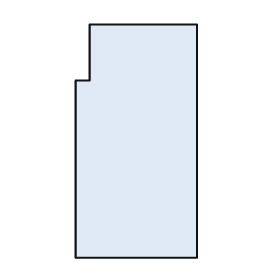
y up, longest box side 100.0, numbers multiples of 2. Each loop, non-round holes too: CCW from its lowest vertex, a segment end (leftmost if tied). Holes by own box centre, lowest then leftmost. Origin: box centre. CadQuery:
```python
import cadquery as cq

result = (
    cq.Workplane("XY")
    .moveTo(-26.0, -50.0)
    .lineTo(26.0, -50.0)
    .lineTo(26.0, 50.0)
    .lineTo(-20.0, 50.0)
    .lineTo(-20.0, 26.0)
    .lineTo(-26.0, 26.0)
    .close()
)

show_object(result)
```